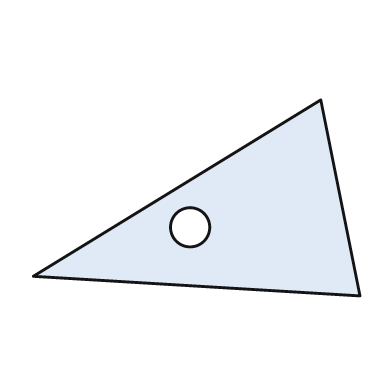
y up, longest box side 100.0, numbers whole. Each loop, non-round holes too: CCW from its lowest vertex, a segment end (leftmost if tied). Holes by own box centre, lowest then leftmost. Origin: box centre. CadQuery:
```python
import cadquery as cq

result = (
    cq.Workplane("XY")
    .moveTo(50.0, -30.0)
    .lineTo(38.0, 30.0)
    .lineTo(-50.0, -24.0)
    .close()
    .moveTo(-2.0, -9.0)
    .circle(6.0)
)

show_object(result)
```